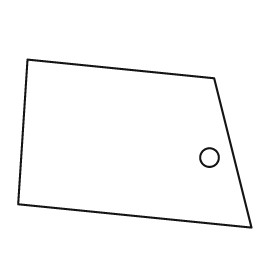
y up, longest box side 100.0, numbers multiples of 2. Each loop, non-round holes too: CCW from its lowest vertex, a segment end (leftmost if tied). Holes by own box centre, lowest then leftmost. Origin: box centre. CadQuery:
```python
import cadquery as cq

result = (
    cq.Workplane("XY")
    .moveTo(50.0, -36.0)
    .lineTo(34.0, 28.0)
    .lineTo(-46.0, 36.0)
    .lineTo(-50.0, -26.0)
    .close()
    .moveTo(32.0, -6.0)
    .circle(4.0)
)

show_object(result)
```